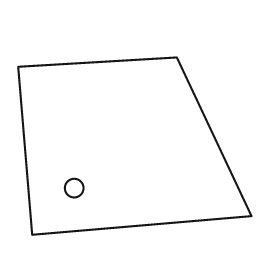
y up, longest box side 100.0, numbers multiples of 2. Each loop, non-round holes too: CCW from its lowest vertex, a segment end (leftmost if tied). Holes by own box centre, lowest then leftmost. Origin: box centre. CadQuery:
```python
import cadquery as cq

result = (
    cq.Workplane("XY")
    .moveTo(-44.0, -38.0)
    .lineTo(50.0, -30.0)
    .lineTo(18.0, 38.0)
    .lineTo(-50.0, 34.0)
    .close()
    .moveTo(-26.0, -18.0)
    .circle(4.0)
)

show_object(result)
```